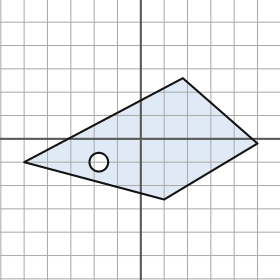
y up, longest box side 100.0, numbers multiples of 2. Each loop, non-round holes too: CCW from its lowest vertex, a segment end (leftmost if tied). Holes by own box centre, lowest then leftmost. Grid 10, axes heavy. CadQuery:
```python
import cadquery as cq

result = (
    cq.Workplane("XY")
    .moveTo(10.0, -26.0)
    .lineTo(50.0, -2.0)
    .lineTo(18.0, 26.0)
    .lineTo(-50.0, -10.0)
    .close()
    .moveTo(-18.0, -10.0)
    .circle(4.0)
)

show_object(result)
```